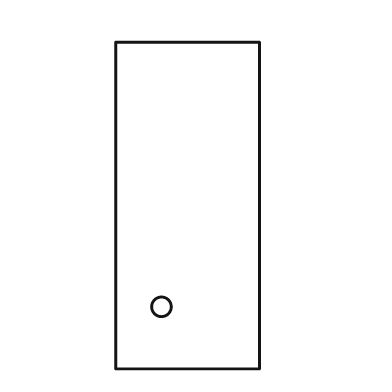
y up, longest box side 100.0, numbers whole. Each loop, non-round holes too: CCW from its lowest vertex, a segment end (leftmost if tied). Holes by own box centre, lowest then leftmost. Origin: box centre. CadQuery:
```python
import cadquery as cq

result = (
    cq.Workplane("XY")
    .moveTo(-22.0, -50.0)
    .lineTo(22.0, -50.0)
    .lineTo(22.0, 50.0)
    .lineTo(-22.0, 50.0)
    .close()
    .moveTo(-8.0, -31.0)
    .circle(3.0)
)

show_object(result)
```